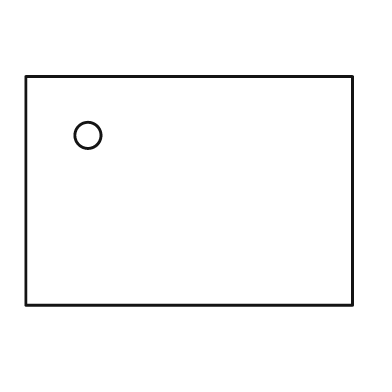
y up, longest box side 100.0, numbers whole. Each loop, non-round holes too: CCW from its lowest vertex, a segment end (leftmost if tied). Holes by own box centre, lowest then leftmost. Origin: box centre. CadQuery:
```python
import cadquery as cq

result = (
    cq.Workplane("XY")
    .moveTo(-50.0, -35.0)
    .lineTo(50.0, -35.0)
    .lineTo(50.0, 35.0)
    .lineTo(-50.0, 35.0)
    .close()
    .moveTo(-31.0, 17.0)
    .circle(4.0)
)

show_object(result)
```